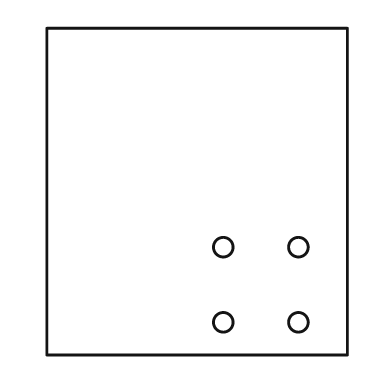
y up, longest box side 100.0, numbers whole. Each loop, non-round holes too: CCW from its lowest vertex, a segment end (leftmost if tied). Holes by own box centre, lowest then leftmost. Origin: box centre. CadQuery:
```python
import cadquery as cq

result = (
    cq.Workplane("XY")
    .moveTo(-46.0, -50.0)
    .lineTo(46.0, -50.0)
    .lineTo(46.0, 50.0)
    .lineTo(-46.0, 50.0)
    .close()
    .moveTo(8.0, -40.0)
    .circle(3.0)
    .moveTo(31.0, -40.0)
    .circle(3.0)
    .moveTo(8.0, -17.0)
    .circle(3.0)
    .moveTo(31.0, -17.0)
    .circle(3.0)
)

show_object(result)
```